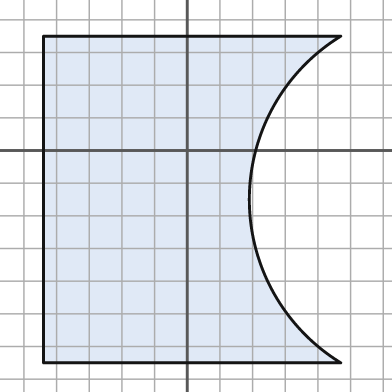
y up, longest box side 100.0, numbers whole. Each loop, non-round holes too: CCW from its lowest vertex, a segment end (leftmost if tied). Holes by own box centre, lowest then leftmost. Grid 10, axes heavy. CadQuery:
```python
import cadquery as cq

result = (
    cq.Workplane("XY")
    .moveTo(-44.0, -65.0)
    .lineTo(47.0, -65.0)
    .threePointArc((19.0, -15.0), (47.0, 35.0))
    .lineTo(-44.0, 35.0)
    .close()
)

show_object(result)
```